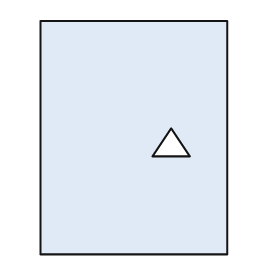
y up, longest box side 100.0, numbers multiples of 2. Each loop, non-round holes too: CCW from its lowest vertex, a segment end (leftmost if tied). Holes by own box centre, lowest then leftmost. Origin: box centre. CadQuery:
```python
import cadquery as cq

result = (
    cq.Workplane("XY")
    .moveTo(-40.0, -50.0)
    .lineTo(40.0, -50.0)
    .lineTo(40.0, 50.0)
    .lineTo(-40.0, 50.0)
    .close()
    .moveTo(8.0, -8.0)
    .lineTo(24.0, -8.0)
    .lineTo(16.0, 4.0)
    .close()
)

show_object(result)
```